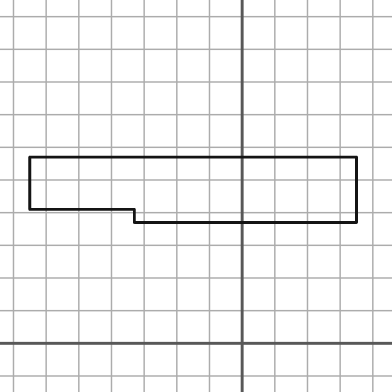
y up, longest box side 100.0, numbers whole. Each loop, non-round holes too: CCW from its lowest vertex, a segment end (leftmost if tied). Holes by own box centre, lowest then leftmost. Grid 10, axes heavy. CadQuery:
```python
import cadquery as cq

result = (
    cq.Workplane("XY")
    .moveTo(-33.0, 37.0)
    .lineTo(35.0, 37.0)
    .lineTo(35.0, 57.0)
    .lineTo(-65.0, 57.0)
    .lineTo(-65.0, 41.0)
    .lineTo(-33.0, 41.0)
    .close()
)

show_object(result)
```